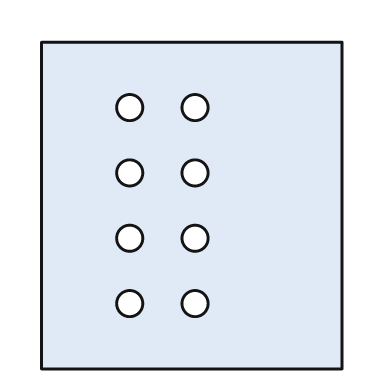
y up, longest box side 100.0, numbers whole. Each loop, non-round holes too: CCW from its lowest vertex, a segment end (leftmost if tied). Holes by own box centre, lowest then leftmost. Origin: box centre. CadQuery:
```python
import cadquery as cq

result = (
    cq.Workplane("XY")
    .moveTo(-46.0, -50.0)
    .lineTo(46.0, -50.0)
    .lineTo(46.0, 50.0)
    .lineTo(-46.0, 50.0)
    .close()
    .moveTo(-19.0, -30.0)
    .circle(4.0)
    .moveTo(1.0, -30.0)
    .circle(4.0)
    .moveTo(-19.0, -10.0)
    .circle(4.0)
    .moveTo(1.0, -10.0)
    .circle(4.0)
    .moveTo(-19.0, 10.0)
    .circle(4.0)
    .moveTo(1.0, 10.0)
    .circle(4.0)
    .moveTo(-19.0, 30.0)
    .circle(4.0)
    .moveTo(1.0, 30.0)
    .circle(4.0)
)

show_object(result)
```